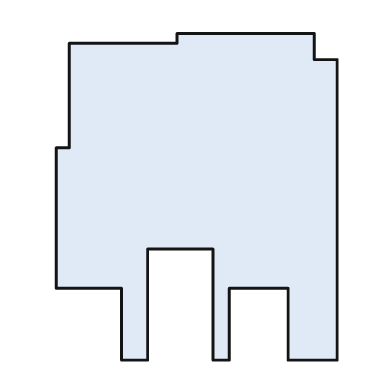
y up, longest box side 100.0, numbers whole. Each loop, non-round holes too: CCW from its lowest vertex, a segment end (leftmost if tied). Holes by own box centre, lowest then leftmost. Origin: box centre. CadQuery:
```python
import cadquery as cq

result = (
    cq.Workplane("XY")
    .moveTo(-23.0, -50.0)
    .lineTo(-15.0, -50.0)
    .lineTo(-15.0, -16.0)
    .lineTo(5.0, -16.0)
    .lineTo(5.0, -50.0)
    .lineTo(10.0, -50.0)
    .lineTo(10.0, -28.0)
    .lineTo(28.0, -28.0)
    .lineTo(28.0, -50.0)
    .lineTo(43.0, -50.0)
    .lineTo(43.0, 42.0)
    .lineTo(36.0, 42.0)
    .lineTo(36.0, 50.0)
    .lineTo(-6.0, 50.0)
    .lineTo(-6.0, 47.0)
    .lineTo(-39.0, 47.0)
    .lineTo(-39.0, 15.0)
    .lineTo(-43.0, 15.0)
    .lineTo(-43.0, -28.0)
    .lineTo(-23.0, -28.0)
    .close()
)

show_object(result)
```